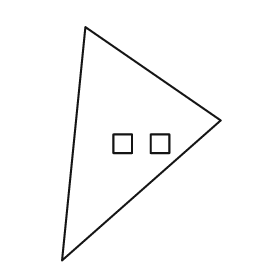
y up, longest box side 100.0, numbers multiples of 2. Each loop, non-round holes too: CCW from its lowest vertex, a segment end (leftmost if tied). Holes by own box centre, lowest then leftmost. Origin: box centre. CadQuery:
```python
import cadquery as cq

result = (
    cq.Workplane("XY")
    .moveTo(-34.0, -50.0)
    .lineTo(34.0, 10.0)
    .lineTo(-24.0, 50.0)
    .close()
    .moveTo(-12.0, -4.0)
    .lineTo(-4.0, -4.0)
    .lineTo(-4.0, 4.0)
    .lineTo(-12.0, 4.0)
    .close()
    .moveTo(4.0, -4.0)
    .lineTo(12.0, -4.0)
    .lineTo(12.0, 4.0)
    .lineTo(4.0, 4.0)
    .close()
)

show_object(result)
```